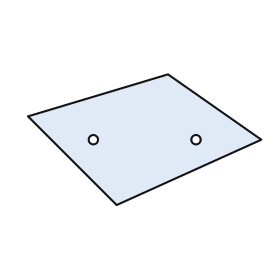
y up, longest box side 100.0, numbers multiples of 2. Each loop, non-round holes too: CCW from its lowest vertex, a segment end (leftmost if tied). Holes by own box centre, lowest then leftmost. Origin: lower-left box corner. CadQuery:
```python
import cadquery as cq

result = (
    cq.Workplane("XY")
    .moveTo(38.0, 0.0)
    .lineTo(100.0, 28.0)
    .lineTo(60.0, 56.0)
    .lineTo(0.0, 38.0)
    .close()
    .moveTo(28.0, 28.0)
    .circle(2.0)
    .moveTo(72.0, 28.0)
    .circle(2.0)
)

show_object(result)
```